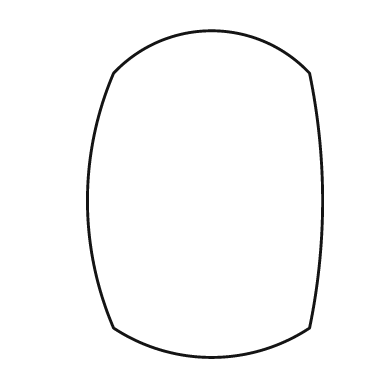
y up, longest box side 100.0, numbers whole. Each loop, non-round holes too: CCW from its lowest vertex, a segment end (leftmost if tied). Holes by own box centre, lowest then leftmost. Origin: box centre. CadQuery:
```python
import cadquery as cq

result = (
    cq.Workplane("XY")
    .moveTo(-28.0, -41.0)
    .threePointArc((2.0, -50.0), (32.0, -41.0))
    .threePointArc((36.0, -2.0), (32.0, 37.0))
    .threePointArc((2.0, 50.0), (-28.0, 37.0))
    .threePointArc((-36.0, -2.0), (-28.0, -41.0))
    .close()
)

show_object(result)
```